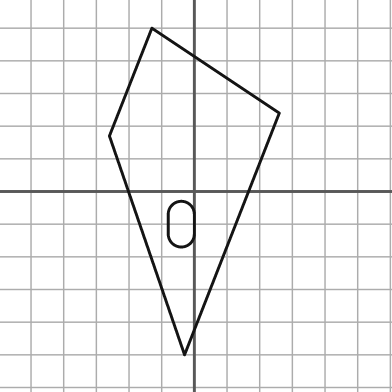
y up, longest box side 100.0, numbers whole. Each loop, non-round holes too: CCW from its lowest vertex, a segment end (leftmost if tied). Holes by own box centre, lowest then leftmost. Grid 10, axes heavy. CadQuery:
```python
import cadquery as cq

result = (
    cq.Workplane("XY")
    .moveTo(-3.0, -50.0)
    .lineTo(26.0, 24.0)
    .lineTo(-13.0, 50.0)
    .lineTo(-26.0, 17.0)
    .close()
    .moveTo(-8.0, -13.0)
    .threePointArc((-4.0, -17.0), (0.0, -13.0))
    .lineTo(0.0, -7.0)
    .threePointArc((-4.0, -3.0), (-8.0, -7.0))
    .close()
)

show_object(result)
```